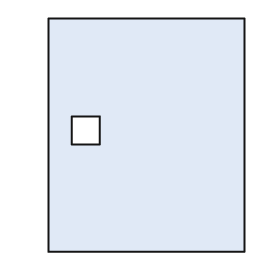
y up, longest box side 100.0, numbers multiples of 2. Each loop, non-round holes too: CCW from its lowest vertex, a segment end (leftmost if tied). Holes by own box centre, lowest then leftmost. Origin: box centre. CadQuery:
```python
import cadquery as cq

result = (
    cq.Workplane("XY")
    .moveTo(-42.0, -50.0)
    .lineTo(42.0, -50.0)
    .lineTo(42.0, 50.0)
    .lineTo(-42.0, 50.0)
    .close()
    .moveTo(-32.0, -4.0)
    .lineTo(-20.0, -4.0)
    .lineTo(-20.0, 8.0)
    .lineTo(-32.0, 8.0)
    .close()
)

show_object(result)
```